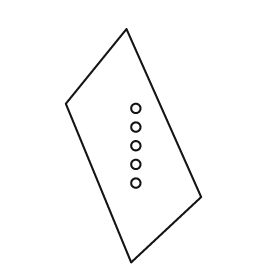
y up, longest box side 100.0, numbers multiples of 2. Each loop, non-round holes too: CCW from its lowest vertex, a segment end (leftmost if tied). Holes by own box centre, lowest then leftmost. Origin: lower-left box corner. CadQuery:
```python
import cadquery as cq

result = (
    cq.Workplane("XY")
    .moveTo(28.0, 0.0)
    .lineTo(58.0, 28.0)
    .lineTo(26.0, 100.0)
    .lineTo(0.0, 68.0)
    .close()
    .moveTo(30.0, 34.0)
    .circle(2.0)
    .moveTo(30.0, 42.0)
    .circle(2.0)
    .moveTo(30.0, 50.0)
    .circle(2.0)
    .moveTo(30.0, 58.0)
    .circle(2.0)
    .moveTo(30.0, 66.0)
    .circle(2.0)
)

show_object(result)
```